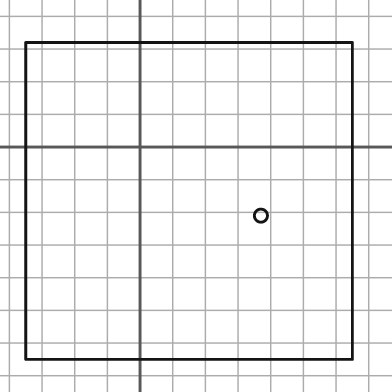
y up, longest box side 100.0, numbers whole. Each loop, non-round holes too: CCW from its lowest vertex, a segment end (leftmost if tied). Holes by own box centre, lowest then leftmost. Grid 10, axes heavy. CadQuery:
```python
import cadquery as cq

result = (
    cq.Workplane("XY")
    .moveTo(-35.0, -65.0)
    .lineTo(65.0, -65.0)
    .lineTo(65.0, 32.0)
    .lineTo(-35.0, 32.0)
    .close()
    .moveTo(37.0, -21.0)
    .circle(2.0)
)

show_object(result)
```